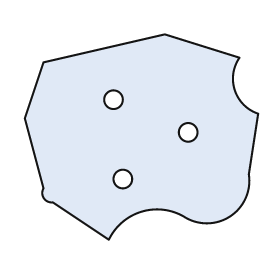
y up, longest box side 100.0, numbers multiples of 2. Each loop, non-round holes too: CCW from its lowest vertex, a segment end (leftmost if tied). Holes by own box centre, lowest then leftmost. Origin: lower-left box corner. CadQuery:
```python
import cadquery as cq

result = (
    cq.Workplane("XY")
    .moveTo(36.0, 0.0)
    .threePointArc((50.0, 12.0), (68.0, 10.0))
    .threePointArc((88.0, 10.0), (96.0, 28.0))
    .lineTo(100.0, 54.0)
    .threePointArc((90.0, 64.0), (92.0, 78.0))
    .lineTo(60.0, 88.0)
    .lineTo(8.0, 76.0)
    .lineTo(0.0, 52.0)
    .lineTo(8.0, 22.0)
    .threePointArc((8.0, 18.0), (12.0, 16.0))
    .close()
    .moveTo(42.0, 26.0)
    .circle(4.0)
    .moveTo(70.0, 46.0)
    .circle(4.0)
    .moveTo(38.0, 60.0)
    .circle(4.0)
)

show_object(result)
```